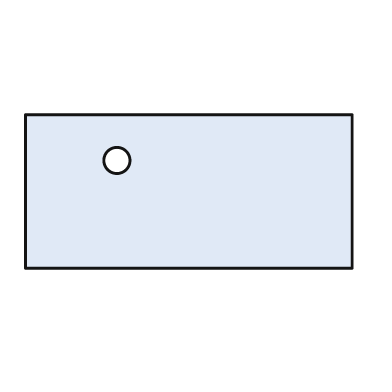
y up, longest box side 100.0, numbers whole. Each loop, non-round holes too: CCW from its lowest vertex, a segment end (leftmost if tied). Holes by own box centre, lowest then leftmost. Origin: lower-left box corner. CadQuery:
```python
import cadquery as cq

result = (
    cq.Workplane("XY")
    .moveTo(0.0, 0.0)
    .lineTo(100.0, 0.0)
    .lineTo(100.0, 47.0)
    .lineTo(0.0, 47.0)
    .close()
    .moveTo(28.0, 33.0)
    .circle(4.0)
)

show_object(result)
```